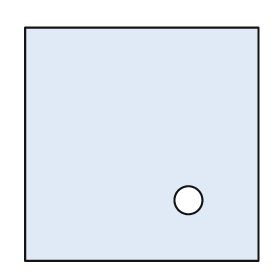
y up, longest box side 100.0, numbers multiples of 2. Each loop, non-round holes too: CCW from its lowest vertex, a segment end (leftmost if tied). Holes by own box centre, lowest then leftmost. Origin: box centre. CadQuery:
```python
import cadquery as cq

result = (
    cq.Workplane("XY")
    .moveTo(-50.0, -50.0)
    .lineTo(50.0, -50.0)
    .lineTo(50.0, 50.0)
    .lineTo(-50.0, 50.0)
    .close()
    .moveTo(20.0, -24.0)
    .circle(6.0)
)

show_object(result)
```